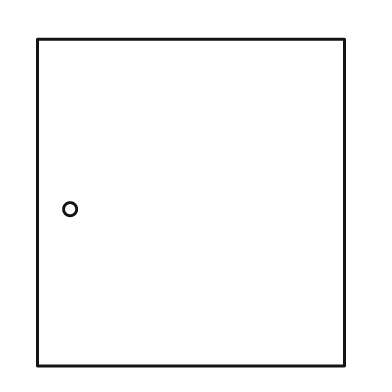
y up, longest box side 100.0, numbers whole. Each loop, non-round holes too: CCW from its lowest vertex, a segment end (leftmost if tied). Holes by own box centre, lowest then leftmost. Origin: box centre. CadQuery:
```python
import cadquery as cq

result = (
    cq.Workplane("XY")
    .moveTo(-47.0, -50.0)
    .lineTo(47.0, -50.0)
    .lineTo(47.0, 50.0)
    .lineTo(-47.0, 50.0)
    .close()
    .moveTo(-37.0, -2.0)
    .circle(2.0)
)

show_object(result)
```